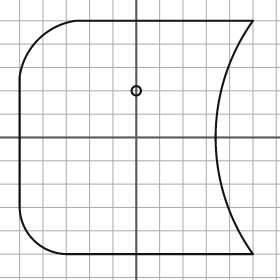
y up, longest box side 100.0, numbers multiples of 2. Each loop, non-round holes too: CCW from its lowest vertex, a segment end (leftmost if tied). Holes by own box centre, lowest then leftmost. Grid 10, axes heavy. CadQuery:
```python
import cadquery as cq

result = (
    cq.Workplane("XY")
    .moveTo(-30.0, -50.0)
    .lineTo(50.0, -50.0)
    .threePointArc((34.0, 0.0), (50.0, 50.0))
    .lineTo(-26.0, 50.0)
    .threePointArc((-42.0, 42.0), (-50.0, 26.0))
    .lineTo(-50.0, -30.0)
    .threePointArc((-44.0, -44.0), (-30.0, -50.0))
    .close()
    .moveTo(0.0, 20.0)
    .circle(2.0)
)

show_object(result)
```